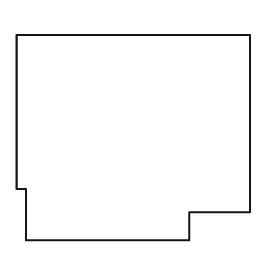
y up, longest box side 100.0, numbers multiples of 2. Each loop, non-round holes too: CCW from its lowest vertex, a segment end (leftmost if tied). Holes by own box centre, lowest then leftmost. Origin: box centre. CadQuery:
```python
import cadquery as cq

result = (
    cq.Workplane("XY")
    .moveTo(-46.0, -44.0)
    .lineTo(24.0, -44.0)
    .lineTo(24.0, -32.0)
    .lineTo(50.0, -32.0)
    .lineTo(50.0, 44.0)
    .lineTo(-50.0, 44.0)
    .lineTo(-50.0, -22.0)
    .lineTo(-46.0, -22.0)
    .close()
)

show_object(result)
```